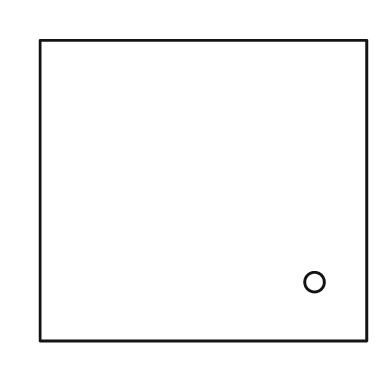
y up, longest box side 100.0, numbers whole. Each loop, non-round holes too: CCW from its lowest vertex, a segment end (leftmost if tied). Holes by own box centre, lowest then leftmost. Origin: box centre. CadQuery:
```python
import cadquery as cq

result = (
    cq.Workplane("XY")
    .moveTo(-50.0, -46.0)
    .lineTo(50.0, -46.0)
    .lineTo(50.0, 46.0)
    .lineTo(-50.0, 46.0)
    .close()
    .moveTo(34.0, -28.0)
    .circle(3.0)
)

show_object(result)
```